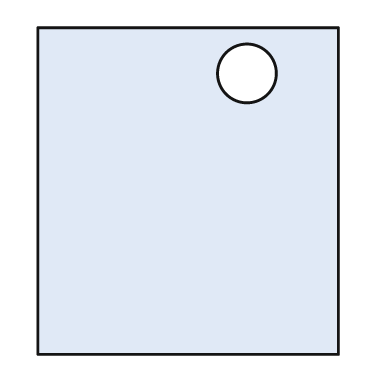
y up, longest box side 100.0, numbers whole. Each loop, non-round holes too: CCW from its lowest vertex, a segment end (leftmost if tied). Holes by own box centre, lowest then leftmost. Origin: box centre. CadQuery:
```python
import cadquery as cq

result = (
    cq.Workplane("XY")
    .moveTo(-46.0, -50.0)
    .lineTo(46.0, -50.0)
    .lineTo(46.0, 50.0)
    .lineTo(-46.0, 50.0)
    .close()
    .moveTo(18.0, 36.0)
    .circle(9.0)
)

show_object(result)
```